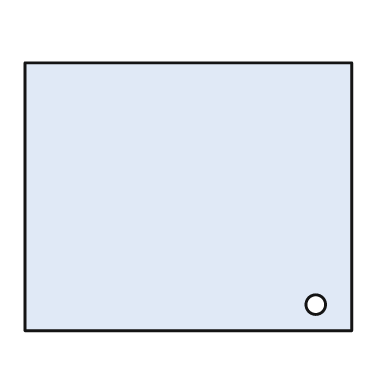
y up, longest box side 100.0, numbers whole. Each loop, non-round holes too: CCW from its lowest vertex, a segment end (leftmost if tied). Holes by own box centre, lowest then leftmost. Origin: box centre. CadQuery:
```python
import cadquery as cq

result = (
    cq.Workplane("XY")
    .moveTo(-50.0, -41.0)
    .lineTo(50.0, -41.0)
    .lineTo(50.0, 41.0)
    .lineTo(-50.0, 41.0)
    .close()
    .moveTo(39.0, -33.0)
    .circle(3.0)
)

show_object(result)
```